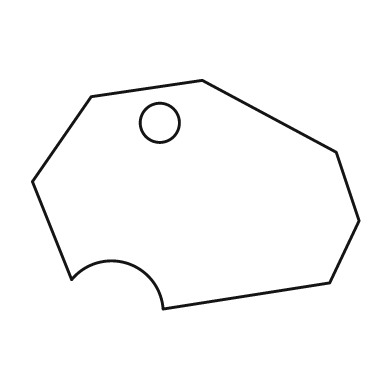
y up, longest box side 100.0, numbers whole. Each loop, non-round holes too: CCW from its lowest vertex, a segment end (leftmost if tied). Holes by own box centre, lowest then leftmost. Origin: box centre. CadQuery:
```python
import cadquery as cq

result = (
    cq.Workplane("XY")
    .moveTo(-10.0, -35.0)
    .lineTo(41.0, -27.0)
    .lineTo(50.0, -8.0)
    .lineTo(43.0, 13.0)
    .lineTo(2.0, 35.0)
    .lineTo(-32.0, 30.0)
    .lineTo(-50.0, 4.0)
    .lineTo(-38.0, -26.0)
    .threePointArc((-21.0, -21.0), (-10.0, -35.0))
    .close()
    .moveTo(-11.0, 22.0)
    .circle(6.0)
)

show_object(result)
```